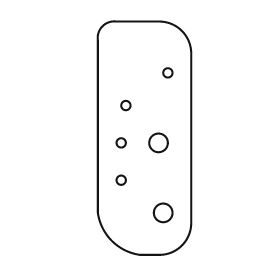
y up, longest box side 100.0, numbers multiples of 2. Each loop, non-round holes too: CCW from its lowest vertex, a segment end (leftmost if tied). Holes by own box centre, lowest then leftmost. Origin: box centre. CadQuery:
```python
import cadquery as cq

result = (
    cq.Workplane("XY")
    .moveTo(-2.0, -50.0)
    .lineTo(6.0, -50.0)
    .threePointArc((16.0, -46.0), (20.0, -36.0))
    .lineTo(20.0, 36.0)
    .threePointArc((16.0, 46.0), (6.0, 50.0))
    .lineTo(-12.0, 50.0)
    .threePointArc((-18.0, 48.0), (-20.0, 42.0))
    .lineTo(-20.0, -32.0)
    .threePointArc((-14.0, -44.0), (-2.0, -50.0))
    .close()
    .moveTo(8.0, -32.0)
    .circle(4.0)
    .moveTo(-10.0, -18.0)
    .circle(2.0)
    .moveTo(-10.0, -2.0)
    .circle(2.0)
    .moveTo(6.0, -2.0)
    .circle(4.0)
    .moveTo(-8.0, 14.0)
    .circle(2.0)
    .moveTo(10.0, 28.0)
    .circle(2.0)
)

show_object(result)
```